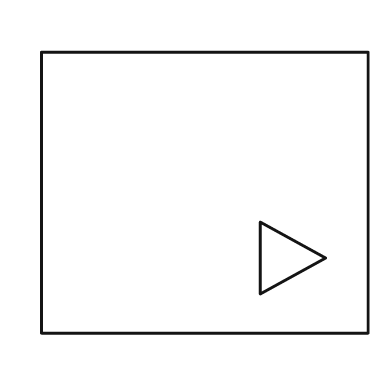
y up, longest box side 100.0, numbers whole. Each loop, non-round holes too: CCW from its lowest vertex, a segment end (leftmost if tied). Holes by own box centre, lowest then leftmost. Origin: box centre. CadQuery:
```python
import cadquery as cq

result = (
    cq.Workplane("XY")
    .moveTo(-50.0, -43.0)
    .lineTo(50.0, -43.0)
    .lineTo(50.0, 43.0)
    .lineTo(-50.0, 43.0)
    .close()
    .moveTo(17.0, -31.0)
    .lineTo(37.0, -20.0)
    .lineTo(17.0, -9.0)
    .close()
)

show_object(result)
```